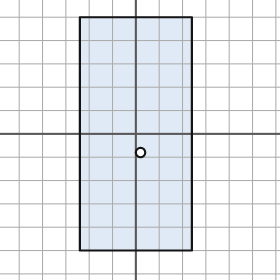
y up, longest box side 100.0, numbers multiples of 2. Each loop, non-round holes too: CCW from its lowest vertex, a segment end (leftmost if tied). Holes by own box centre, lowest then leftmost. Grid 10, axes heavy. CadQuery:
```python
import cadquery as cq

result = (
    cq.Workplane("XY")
    .moveTo(-24.0, -50.0)
    .lineTo(24.0, -50.0)
    .lineTo(24.0, 50.0)
    .lineTo(-24.0, 50.0)
    .close()
    .moveTo(2.0, -8.0)
    .circle(2.0)
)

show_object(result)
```